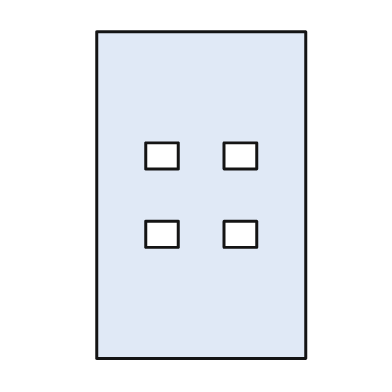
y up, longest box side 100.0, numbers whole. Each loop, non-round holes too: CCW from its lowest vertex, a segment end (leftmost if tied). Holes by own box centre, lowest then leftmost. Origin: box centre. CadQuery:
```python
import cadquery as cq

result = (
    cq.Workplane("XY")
    .moveTo(-32.0, -50.0)
    .lineTo(32.0, -50.0)
    .lineTo(32.0, 50.0)
    .lineTo(-32.0, 50.0)
    .close()
    .moveTo(-17.0, -16.0)
    .lineTo(-7.0, -16.0)
    .lineTo(-7.0, -8.0)
    .lineTo(-17.0, -8.0)
    .close()
    .moveTo(7.0, -16.0)
    .lineTo(17.0, -16.0)
    .lineTo(17.0, -8.0)
    .lineTo(7.0, -8.0)
    .close()
    .moveTo(-17.0, 8.0)
    .lineTo(-7.0, 8.0)
    .lineTo(-7.0, 16.0)
    .lineTo(-17.0, 16.0)
    .close()
    .moveTo(7.0, 8.0)
    .lineTo(17.0, 8.0)
    .lineTo(17.0, 16.0)
    .lineTo(7.0, 16.0)
    .close()
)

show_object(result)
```